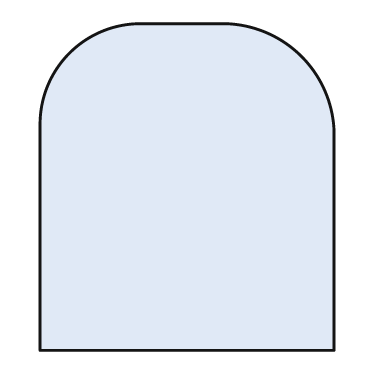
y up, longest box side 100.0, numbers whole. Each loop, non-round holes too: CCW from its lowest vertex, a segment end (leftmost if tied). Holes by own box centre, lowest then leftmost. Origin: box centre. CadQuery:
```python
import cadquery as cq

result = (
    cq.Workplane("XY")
    .moveTo(-45.0, -50.0)
    .lineTo(45.0, -50.0)
    .lineTo(45.0, 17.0)
    .threePointArc((35.0, 40.0), (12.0, 50.0))
    .lineTo(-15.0, 50.0)
    .threePointArc((-36.0, 41.0), (-45.0, 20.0))
    .close()
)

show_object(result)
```